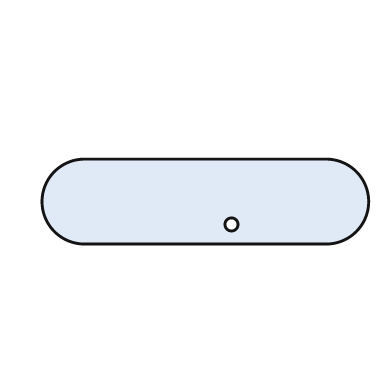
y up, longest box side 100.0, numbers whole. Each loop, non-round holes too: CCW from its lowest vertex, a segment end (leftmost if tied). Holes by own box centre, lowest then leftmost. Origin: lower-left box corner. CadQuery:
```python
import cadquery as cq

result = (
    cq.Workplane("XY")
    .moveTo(13.0, 0.0)
    .lineTo(87.0, 0.0)
    .threePointArc((100.0, 13.0), (87.0, 26.0))
    .lineTo(13.0, 26.0)
    .threePointArc((0.0, 13.0), (13.0, 0.0))
    .close()
    .moveTo(58.0, 6.0)
    .circle(2.0)
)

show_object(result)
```